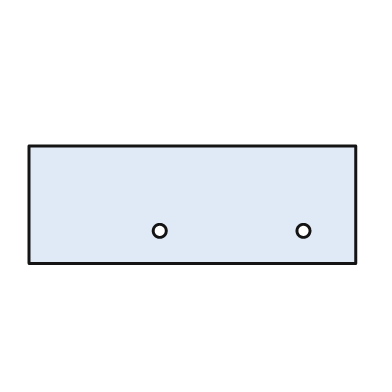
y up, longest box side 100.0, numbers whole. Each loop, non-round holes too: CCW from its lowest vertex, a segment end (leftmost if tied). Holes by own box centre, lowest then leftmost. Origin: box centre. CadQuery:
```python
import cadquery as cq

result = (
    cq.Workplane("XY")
    .moveTo(-50.0, -18.0)
    .lineTo(50.0, -18.0)
    .lineTo(50.0, 18.0)
    .lineTo(-50.0, 18.0)
    .close()
    .moveTo(-10.0, -8.0)
    .circle(2.0)
    .moveTo(34.0, -8.0)
    .circle(2.0)
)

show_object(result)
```